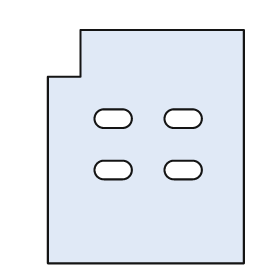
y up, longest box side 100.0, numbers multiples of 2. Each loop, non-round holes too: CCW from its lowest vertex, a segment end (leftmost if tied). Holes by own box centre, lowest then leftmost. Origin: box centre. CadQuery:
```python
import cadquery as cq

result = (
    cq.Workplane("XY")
    .moveTo(-42.0, -50.0)
    .lineTo(42.0, -50.0)
    .lineTo(42.0, 50.0)
    .lineTo(-28.0, 50.0)
    .lineTo(-28.0, 30.0)
    .lineTo(-42.0, 30.0)
    .close()
    .moveTo(-18.0, -14.0)
    .lineTo(-10.0, -14.0)
    .threePointArc((-6.0, -10.0), (-10.0, -6.0))
    .lineTo(-18.0, -6.0)
    .threePointArc((-22.0, -10.0), (-18.0, -14.0))
    .close()
    .moveTo(12.0, -14.0)
    .lineTo(20.0, -14.0)
    .threePointArc((24.0, -10.0), (20.0, -6.0))
    .lineTo(12.0, -6.0)
    .threePointArc((8.0, -10.0), (12.0, -14.0))
    .close()
    .moveTo(-18.0, 8.0)
    .lineTo(-10.0, 8.0)
    .threePointArc((-6.0, 12.0), (-10.0, 16.0))
    .lineTo(-18.0, 16.0)
    .threePointArc((-22.0, 12.0), (-18.0, 8.0))
    .close()
    .moveTo(12.0, 8.0)
    .lineTo(20.0, 8.0)
    .threePointArc((24.0, 12.0), (20.0, 16.0))
    .lineTo(12.0, 16.0)
    .threePointArc((8.0, 12.0), (12.0, 8.0))
    .close()
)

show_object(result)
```